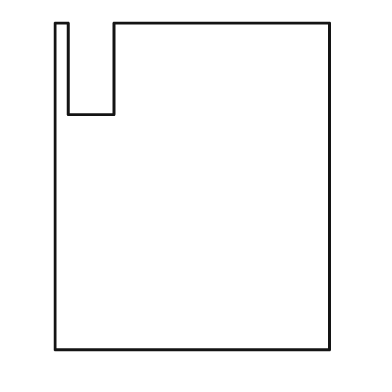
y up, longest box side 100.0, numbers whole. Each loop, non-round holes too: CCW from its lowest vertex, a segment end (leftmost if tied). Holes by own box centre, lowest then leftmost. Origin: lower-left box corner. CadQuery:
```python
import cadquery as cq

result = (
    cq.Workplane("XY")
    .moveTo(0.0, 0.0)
    .lineTo(84.0, 0.0)
    .lineTo(84.0, 100.0)
    .lineTo(18.0, 100.0)
    .lineTo(18.0, 72.0)
    .lineTo(4.0, 72.0)
    .lineTo(4.0, 100.0)
    .lineTo(0.0, 100.0)
    .close()
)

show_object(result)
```